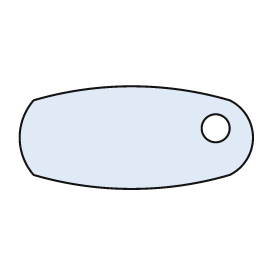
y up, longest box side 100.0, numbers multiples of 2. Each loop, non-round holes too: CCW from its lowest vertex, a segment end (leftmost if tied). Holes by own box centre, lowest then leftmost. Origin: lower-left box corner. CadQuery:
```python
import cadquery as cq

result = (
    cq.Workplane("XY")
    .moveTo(6.0, 6.0)
    .threePointArc((48.0, 0.0), (90.0, 6.0))
    .threePointArc((100.0, 22.0), (90.0, 38.0))
    .threePointArc((48.0, 44.0), (6.0, 38.0))
    .threePointArc((0.0, 22.0), (6.0, 6.0))
    .close()
    .moveTo(84.0, 26.0)
    .circle(6.0)
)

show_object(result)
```